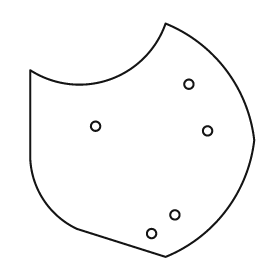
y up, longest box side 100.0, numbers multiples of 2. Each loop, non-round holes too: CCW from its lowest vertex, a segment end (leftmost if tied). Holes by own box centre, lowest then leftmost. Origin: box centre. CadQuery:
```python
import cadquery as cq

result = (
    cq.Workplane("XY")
    .moveTo(10.0, -50.0)
    .threePointArc((36.0, -30.0), (48.0, 0.0))
    .threePointArc((36.0, 30.0), (10.0, 50.0))
    .threePointArc((-14.0, 26.0), (-48.0, 30.0))
    .lineTo(-48.0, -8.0)
    .threePointArc((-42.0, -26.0), (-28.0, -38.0))
    .close()
    .moveTo(4.0, -40.0)
    .circle(2.0)
    .moveTo(14.0, -32.0)
    .circle(2.0)
    .moveTo(28.0, 4.0)
    .circle(2.0)
    .moveTo(-20.0, 6.0)
    .circle(2.0)
    .moveTo(20.0, 24.0)
    .circle(2.0)
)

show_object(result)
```